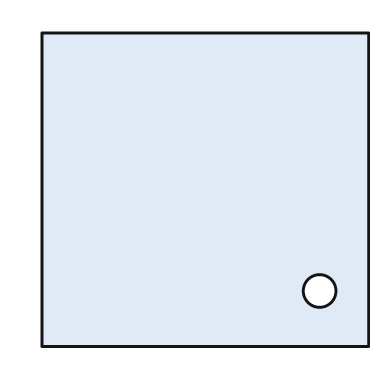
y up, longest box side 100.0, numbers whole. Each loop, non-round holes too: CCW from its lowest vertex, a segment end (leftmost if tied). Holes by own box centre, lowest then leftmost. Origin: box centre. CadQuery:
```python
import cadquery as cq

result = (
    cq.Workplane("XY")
    .moveTo(-50.0, -48.0)
    .lineTo(50.0, -48.0)
    .lineTo(50.0, 48.0)
    .lineTo(-50.0, 48.0)
    .close()
    .moveTo(35.0, -31.0)
    .circle(5.0)
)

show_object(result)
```